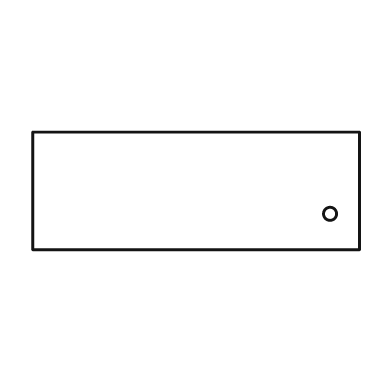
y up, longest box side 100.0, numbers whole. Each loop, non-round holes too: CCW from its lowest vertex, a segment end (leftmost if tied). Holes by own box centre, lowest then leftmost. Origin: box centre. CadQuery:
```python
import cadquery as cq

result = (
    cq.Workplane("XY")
    .moveTo(-50.0, -18.0)
    .lineTo(50.0, -18.0)
    .lineTo(50.0, 18.0)
    .lineTo(-50.0, 18.0)
    .close()
    .moveTo(41.0, -7.0)
    .circle(2.0)
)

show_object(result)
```